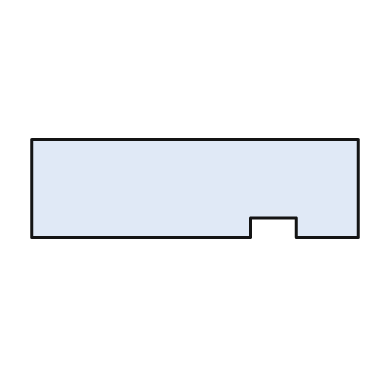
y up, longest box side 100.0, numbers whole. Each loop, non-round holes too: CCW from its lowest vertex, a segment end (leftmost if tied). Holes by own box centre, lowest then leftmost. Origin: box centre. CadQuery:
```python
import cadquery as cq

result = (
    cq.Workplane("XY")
    .moveTo(-50.0, -15.0)
    .lineTo(17.0, -15.0)
    .lineTo(17.0, -9.0)
    .lineTo(31.0, -9.0)
    .lineTo(31.0, -15.0)
    .lineTo(50.0, -15.0)
    .lineTo(50.0, 15.0)
    .lineTo(-50.0, 15.0)
    .close()
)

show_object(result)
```